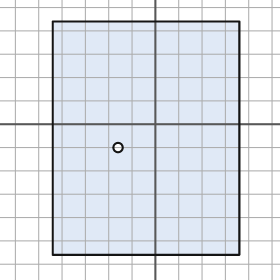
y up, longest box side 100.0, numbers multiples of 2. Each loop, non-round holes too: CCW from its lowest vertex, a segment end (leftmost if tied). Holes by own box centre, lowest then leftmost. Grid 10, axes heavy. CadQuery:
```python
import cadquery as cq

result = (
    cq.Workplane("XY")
    .moveTo(-44.0, -56.0)
    .lineTo(36.0, -56.0)
    .lineTo(36.0, 44.0)
    .lineTo(-44.0, 44.0)
    .close()
    .moveTo(-16.0, -10.0)
    .circle(2.0)
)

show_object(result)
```